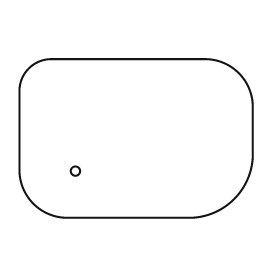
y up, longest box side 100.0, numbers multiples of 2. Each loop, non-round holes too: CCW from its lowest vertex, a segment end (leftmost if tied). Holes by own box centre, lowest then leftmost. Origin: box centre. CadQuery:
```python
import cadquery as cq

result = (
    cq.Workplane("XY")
    .moveTo(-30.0, -34.0)
    .lineTo(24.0, -34.0)
    .threePointArc((42.0, -26.0), (50.0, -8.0))
    .lineTo(50.0, 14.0)
    .threePointArc((44.0, 28.0), (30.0, 34.0))
    .lineTo(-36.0, 34.0)
    .threePointArc((-46.0, 30.0), (-50.0, 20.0))
    .lineTo(-50.0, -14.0)
    .threePointArc((-44.0, -28.0), (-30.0, -34.0))
    .close()
    .moveTo(-26.0, -14.0)
    .circle(2.0)
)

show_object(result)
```